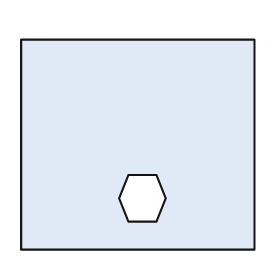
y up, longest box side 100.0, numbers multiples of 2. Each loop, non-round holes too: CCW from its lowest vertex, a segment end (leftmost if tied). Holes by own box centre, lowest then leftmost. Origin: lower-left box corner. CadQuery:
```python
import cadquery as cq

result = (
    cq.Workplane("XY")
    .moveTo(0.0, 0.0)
    .lineTo(100.0, 0.0)
    .lineTo(100.0, 90.0)
    .lineTo(0.0, 90.0)
    .close()
    .moveTo(46.0, 12.0)
    .lineTo(58.0, 12.0)
    .lineTo(62.0, 22.0)
    .lineTo(58.0, 32.0)
    .lineTo(46.0, 32.0)
    .lineTo(42.0, 22.0)
    .close()
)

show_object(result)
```